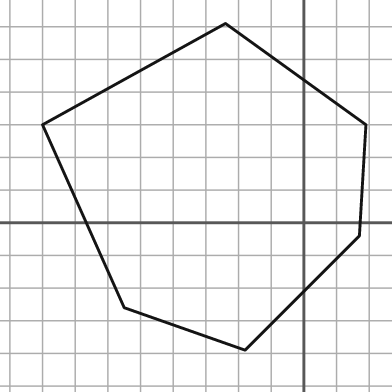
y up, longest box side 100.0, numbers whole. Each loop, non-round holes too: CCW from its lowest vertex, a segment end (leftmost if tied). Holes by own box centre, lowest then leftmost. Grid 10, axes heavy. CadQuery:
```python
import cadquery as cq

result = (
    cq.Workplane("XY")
    .moveTo(-18.0, -39.0)
    .lineTo(17.0, -4.0)
    .lineTo(19.0, 30.0)
    .lineTo(-24.0, 61.0)
    .lineTo(-80.0, 30.0)
    .lineTo(-55.0, -26.0)
    .close()
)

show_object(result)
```